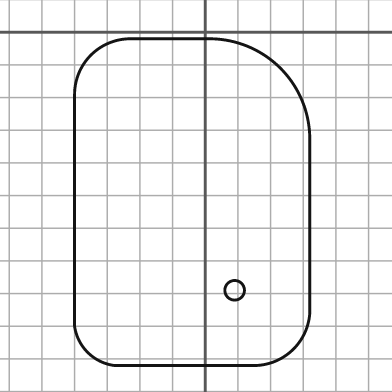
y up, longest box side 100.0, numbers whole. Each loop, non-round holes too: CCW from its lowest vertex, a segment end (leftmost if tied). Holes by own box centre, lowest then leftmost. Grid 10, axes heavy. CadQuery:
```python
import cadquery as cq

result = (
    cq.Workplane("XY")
    .moveTo(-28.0, -102.0)
    .lineTo(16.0, -102.0)
    .threePointArc((27.0, -97.0), (32.0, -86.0))
    .lineTo(32.0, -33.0)
    .threePointArc((23.0, -11.0), (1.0, -2.0))
    .lineTo(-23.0, -2.0)
    .threePointArc((-35.0, -7.0), (-40.0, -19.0))
    .lineTo(-40.0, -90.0)
    .threePointArc((-36.0, -98.0), (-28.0, -102.0))
    .close()
    .moveTo(9.0, -79.0)
    .circle(3.0)
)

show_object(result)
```